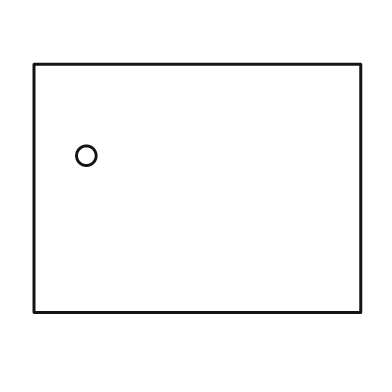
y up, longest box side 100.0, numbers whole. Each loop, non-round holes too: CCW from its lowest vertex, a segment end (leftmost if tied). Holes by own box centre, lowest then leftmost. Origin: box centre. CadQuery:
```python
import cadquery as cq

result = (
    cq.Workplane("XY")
    .moveTo(-50.0, -38.0)
    .lineTo(50.0, -38.0)
    .lineTo(50.0, 38.0)
    .lineTo(-50.0, 38.0)
    .close()
    .moveTo(-34.0, 10.0)
    .circle(3.0)
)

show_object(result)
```